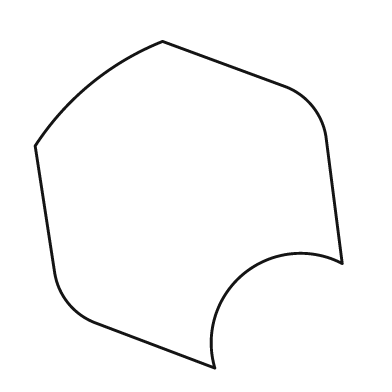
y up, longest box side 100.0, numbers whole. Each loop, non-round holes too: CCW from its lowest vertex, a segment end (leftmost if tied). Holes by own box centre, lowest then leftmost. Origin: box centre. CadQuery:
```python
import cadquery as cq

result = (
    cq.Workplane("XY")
    .moveTo(8.0, -50.0)
    .threePointArc((17.0, -21.0), (47.0, -18.0))
    .lineTo(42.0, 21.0)
    .threePointArc((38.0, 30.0), (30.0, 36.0))
    .lineTo(-8.0, 50.0)
    .threePointArc((-30.0, 37.0), (-47.0, 18.0))
    .lineTo(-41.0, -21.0)
    .threePointArc((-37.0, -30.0), (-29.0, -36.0))
    .close()
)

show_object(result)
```